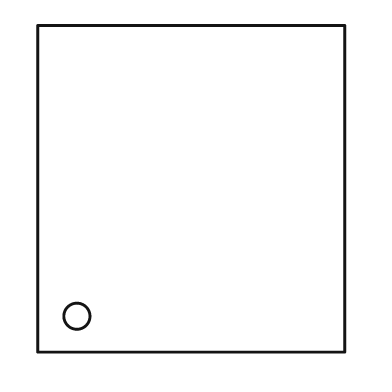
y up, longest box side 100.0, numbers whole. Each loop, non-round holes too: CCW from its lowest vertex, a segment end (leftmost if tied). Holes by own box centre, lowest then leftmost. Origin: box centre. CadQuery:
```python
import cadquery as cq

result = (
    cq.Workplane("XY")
    .moveTo(-47.0, -50.0)
    .lineTo(47.0, -50.0)
    .lineTo(47.0, 50.0)
    .lineTo(-47.0, 50.0)
    .close()
    .moveTo(-35.0, -39.0)
    .circle(4.0)
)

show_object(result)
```